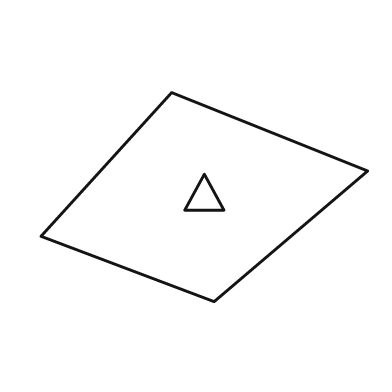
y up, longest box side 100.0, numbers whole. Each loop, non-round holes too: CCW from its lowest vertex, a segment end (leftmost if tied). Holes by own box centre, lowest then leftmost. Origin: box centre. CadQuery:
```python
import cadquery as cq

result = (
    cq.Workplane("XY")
    .moveTo(3.0, -32.0)
    .lineTo(50.0, 8.0)
    .lineTo(-10.0, 32.0)
    .lineTo(-50.0, -12.0)
    .close()
    .moveTo(-6.0, -4.0)
    .lineTo(6.0, -4.0)
    .lineTo(0.0, 7.0)
    .close()
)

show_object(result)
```